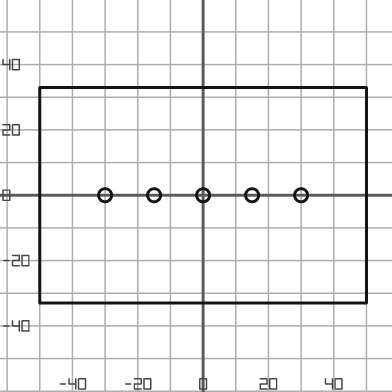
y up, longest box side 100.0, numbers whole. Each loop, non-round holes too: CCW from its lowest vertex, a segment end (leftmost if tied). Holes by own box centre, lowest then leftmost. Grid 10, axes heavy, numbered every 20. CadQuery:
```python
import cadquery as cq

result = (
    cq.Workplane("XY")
    .moveTo(-50.0, -33.0)
    .lineTo(50.0, -33.0)
    .lineTo(50.0, 33.0)
    .lineTo(-50.0, 33.0)
    .close()
    .moveTo(-30.0, 0.0)
    .circle(2.0)
    .moveTo(-15.0, 0.0)
    .circle(2.0)
    .moveTo(0.0, 0.0)
    .circle(2.0)
    .moveTo(15.0, 0.0)
    .circle(2.0)
    .moveTo(30.0, 0.0)
    .circle(2.0)
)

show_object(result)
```